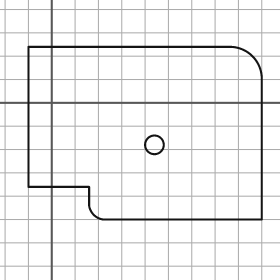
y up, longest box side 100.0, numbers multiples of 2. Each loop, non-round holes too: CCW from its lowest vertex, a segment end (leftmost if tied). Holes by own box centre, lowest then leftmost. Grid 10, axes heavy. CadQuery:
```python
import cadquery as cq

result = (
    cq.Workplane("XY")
    .moveTo(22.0, -50.0)
    .lineTo(90.0, -50.0)
    .lineTo(90.0, 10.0)
    .threePointArc((86.0, 20.0), (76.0, 24.0))
    .lineTo(-10.0, 24.0)
    .lineTo(-10.0, -36.0)
    .lineTo(16.0, -36.0)
    .lineTo(16.0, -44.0)
    .threePointArc((18.0, -48.0), (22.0, -50.0))
    .close()
    .moveTo(44.0, -18.0)
    .circle(4.0)
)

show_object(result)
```